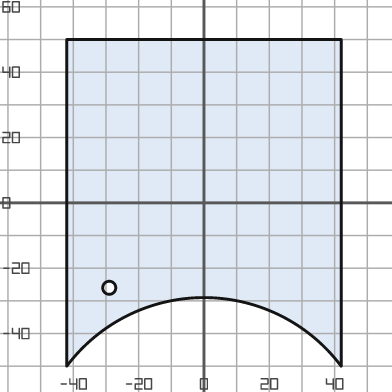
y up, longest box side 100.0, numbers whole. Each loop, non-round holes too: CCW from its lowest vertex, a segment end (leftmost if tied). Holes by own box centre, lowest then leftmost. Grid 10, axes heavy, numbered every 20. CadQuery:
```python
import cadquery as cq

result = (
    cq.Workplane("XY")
    .moveTo(-42.0, -50.0)
    .threePointArc((0.0, -29.0), (42.0, -50.0))
    .lineTo(42.0, 50.0)
    .lineTo(-42.0, 50.0)
    .close()
    .moveTo(-29.0, -26.0)
    .circle(2.0)
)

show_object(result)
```